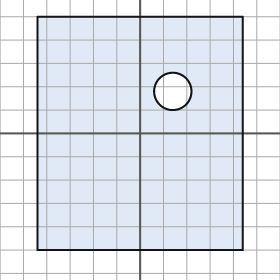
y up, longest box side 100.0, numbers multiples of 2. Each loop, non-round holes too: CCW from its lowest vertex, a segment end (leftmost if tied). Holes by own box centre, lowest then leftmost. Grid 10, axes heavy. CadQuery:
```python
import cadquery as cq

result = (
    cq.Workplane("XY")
    .moveTo(-44.0, -50.0)
    .lineTo(44.0, -50.0)
    .lineTo(44.0, 50.0)
    .lineTo(-44.0, 50.0)
    .close()
    .moveTo(14.0, 18.0)
    .circle(8.0)
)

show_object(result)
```